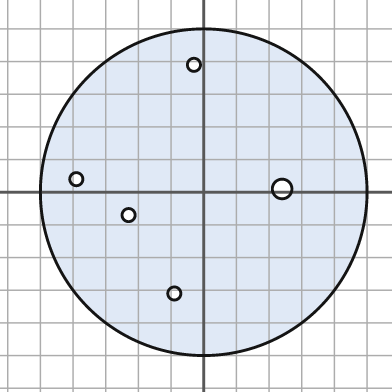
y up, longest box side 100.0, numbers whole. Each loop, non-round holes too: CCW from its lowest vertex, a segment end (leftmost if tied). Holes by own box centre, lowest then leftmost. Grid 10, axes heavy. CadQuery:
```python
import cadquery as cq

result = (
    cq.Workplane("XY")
    .moveTo(0.0, 0.0)
    .circle(50.0)
    .moveTo(-9.0, -31.0)
    .circle(2.0)
    .moveTo(-23.0, -7.0)
    .circle(2.0)
    .moveTo(24.0, 1.0)
    .circle(3.0)
    .moveTo(-39.0, 4.0)
    .circle(2.0)
    .moveTo(-3.0, 39.0)
    .circle(2.0)
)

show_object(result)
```